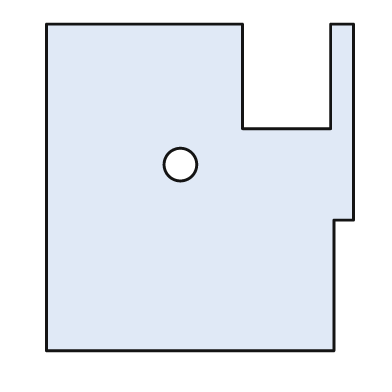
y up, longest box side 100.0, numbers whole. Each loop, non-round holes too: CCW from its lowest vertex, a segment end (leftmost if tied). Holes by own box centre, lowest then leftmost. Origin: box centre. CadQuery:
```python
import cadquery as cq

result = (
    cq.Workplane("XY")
    .moveTo(-47.0, -50.0)
    .lineTo(41.0, -50.0)
    .lineTo(41.0, -10.0)
    .lineTo(47.0, -10.0)
    .lineTo(47.0, 50.0)
    .lineTo(40.0, 50.0)
    .lineTo(40.0, 18.0)
    .lineTo(13.0, 18.0)
    .lineTo(13.0, 50.0)
    .lineTo(-47.0, 50.0)
    .close()
    .moveTo(-6.0, 7.0)
    .circle(5.0)
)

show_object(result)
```